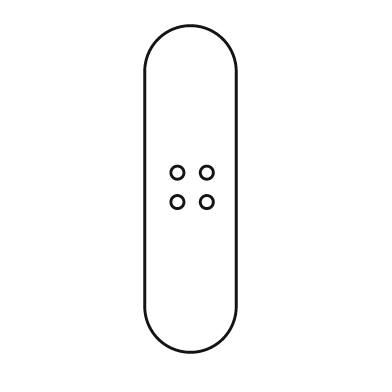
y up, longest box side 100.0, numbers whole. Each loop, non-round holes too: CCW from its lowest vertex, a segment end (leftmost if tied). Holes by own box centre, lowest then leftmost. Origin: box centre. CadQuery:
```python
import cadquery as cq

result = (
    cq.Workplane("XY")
    .moveTo(-14.0, -36.0)
    .threePointArc((0.0, -50.0), (14.0, -36.0))
    .lineTo(14.0, 36.0)
    .threePointArc((0.0, 50.0), (-14.0, 36.0))
    .close()
    .moveTo(-4.0, -4.0)
    .circle(2.0)
    .moveTo(5.0, -4.0)
    .circle(2.0)
    .moveTo(-4.0, 5.0)
    .circle(2.0)
    .moveTo(5.0, 5.0)
    .circle(2.0)
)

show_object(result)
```